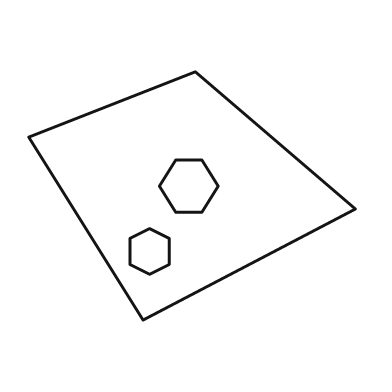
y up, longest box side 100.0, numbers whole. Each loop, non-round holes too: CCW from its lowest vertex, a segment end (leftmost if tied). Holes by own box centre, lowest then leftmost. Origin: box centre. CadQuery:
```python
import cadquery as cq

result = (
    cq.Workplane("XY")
    .moveTo(-15.0, -38.0)
    .lineTo(50.0, -4.0)
    .lineTo(1.0, 38.0)
    .lineTo(-50.0, 18.0)
    .close()
    .moveTo(-13.0, -24.0)
    .lineTo(-7.0, -21.0)
    .lineTo(-7.0, -13.0)
    .lineTo(-13.0, -10.0)
    .lineTo(-19.0, -13.0)
    .lineTo(-19.0, -21.0)
    .close()
    .moveTo(-5.0, -5.0)
    .lineTo(3.0, -5.0)
    .lineTo(8.0, 3.0)
    .lineTo(3.0, 11.0)
    .lineTo(-5.0, 11.0)
    .lineTo(-10.0, 3.0)
    .close()
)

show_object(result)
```